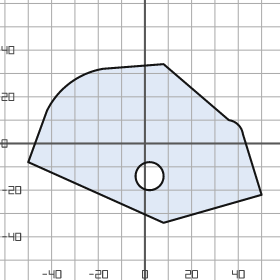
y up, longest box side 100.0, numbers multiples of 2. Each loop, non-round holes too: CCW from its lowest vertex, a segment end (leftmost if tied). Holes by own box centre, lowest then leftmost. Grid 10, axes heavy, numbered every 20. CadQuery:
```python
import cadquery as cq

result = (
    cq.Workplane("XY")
    .moveTo(8.0, -34.0)
    .lineTo(50.0, -22.0)
    .lineTo(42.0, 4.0)
    .threePointArc((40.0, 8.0), (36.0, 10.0))
    .lineTo(8.0, 34.0)
    .lineTo(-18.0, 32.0)
    .threePointArc((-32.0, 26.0), (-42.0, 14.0))
    .lineTo(-50.0, -8.0)
    .close()
    .moveTo(2.0, -14.0)
    .circle(6.0)
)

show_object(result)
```